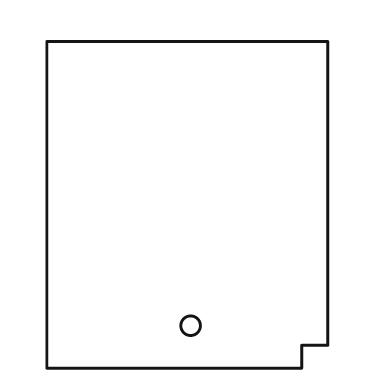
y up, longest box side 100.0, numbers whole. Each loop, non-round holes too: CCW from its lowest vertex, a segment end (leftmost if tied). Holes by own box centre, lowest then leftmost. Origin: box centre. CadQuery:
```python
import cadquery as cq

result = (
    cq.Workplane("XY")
    .moveTo(-43.0, -50.0)
    .lineTo(35.0, -50.0)
    .lineTo(35.0, -43.0)
    .lineTo(43.0, -43.0)
    .lineTo(43.0, 50.0)
    .lineTo(-43.0, 50.0)
    .close()
    .moveTo(1.0, -37.0)
    .circle(3.0)
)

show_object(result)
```